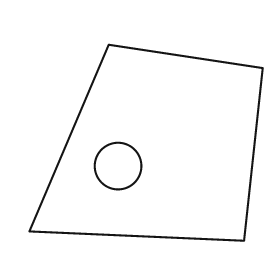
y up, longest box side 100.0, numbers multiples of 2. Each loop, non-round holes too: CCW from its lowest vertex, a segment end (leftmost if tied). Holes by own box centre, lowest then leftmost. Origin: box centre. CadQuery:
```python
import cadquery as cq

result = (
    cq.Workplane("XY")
    .moveTo(42.0, -42.0)
    .lineTo(50.0, 32.0)
    .lineTo(-16.0, 42.0)
    .lineTo(-50.0, -38.0)
    .close()
    .moveTo(-12.0, -10.0)
    .circle(10.0)
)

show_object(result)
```